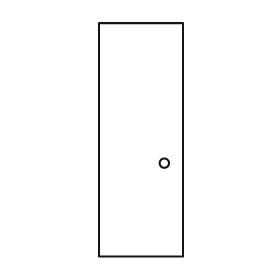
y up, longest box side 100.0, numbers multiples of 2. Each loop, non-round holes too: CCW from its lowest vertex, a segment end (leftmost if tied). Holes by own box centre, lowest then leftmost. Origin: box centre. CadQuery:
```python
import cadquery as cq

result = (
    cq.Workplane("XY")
    .moveTo(-18.0, -50.0)
    .lineTo(18.0, -50.0)
    .lineTo(18.0, 50.0)
    .lineTo(-18.0, 50.0)
    .close()
    .moveTo(10.0, -10.0)
    .circle(2.0)
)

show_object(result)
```